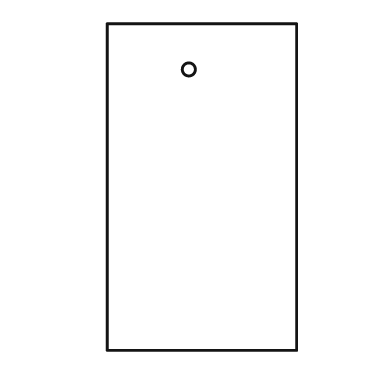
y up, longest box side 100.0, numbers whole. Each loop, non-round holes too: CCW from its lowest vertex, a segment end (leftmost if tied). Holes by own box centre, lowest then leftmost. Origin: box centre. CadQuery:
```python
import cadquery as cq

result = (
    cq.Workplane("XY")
    .moveTo(-29.0, -50.0)
    .lineTo(29.0, -50.0)
    .lineTo(29.0, 50.0)
    .lineTo(-29.0, 50.0)
    .close()
    .moveTo(-4.0, 36.0)
    .circle(2.0)
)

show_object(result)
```